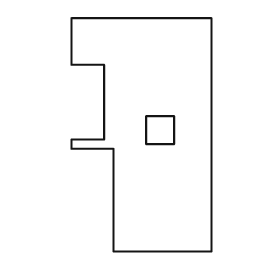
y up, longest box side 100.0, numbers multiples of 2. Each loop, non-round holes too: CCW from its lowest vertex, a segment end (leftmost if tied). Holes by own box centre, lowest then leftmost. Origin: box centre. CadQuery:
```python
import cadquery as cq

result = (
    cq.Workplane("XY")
    .moveTo(-12.0, -50.0)
    .lineTo(30.0, -50.0)
    .lineTo(30.0, 50.0)
    .lineTo(-30.0, 50.0)
    .lineTo(-30.0, 30.0)
    .lineTo(-16.0, 30.0)
    .lineTo(-16.0, -2.0)
    .lineTo(-30.0, -2.0)
    .lineTo(-30.0, -6.0)
    .lineTo(-12.0, -6.0)
    .close()
    .moveTo(2.0, -4.0)
    .lineTo(14.0, -4.0)
    .lineTo(14.0, 8.0)
    .lineTo(2.0, 8.0)
    .close()
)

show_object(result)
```